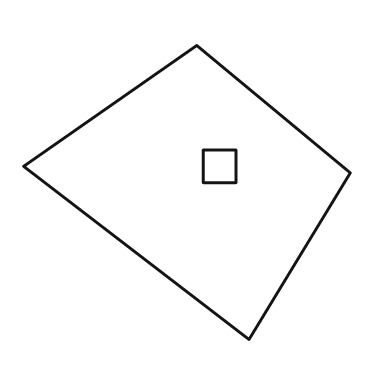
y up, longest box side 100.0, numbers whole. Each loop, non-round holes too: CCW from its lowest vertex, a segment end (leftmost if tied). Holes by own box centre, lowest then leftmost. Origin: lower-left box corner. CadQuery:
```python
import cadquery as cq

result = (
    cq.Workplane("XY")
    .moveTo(69.0, 0.0)
    .lineTo(100.0, 51.0)
    .lineTo(53.0, 90.0)
    .lineTo(0.0, 53.0)
    .close()
    .moveTo(55.0, 48.0)
    .lineTo(65.0, 48.0)
    .lineTo(65.0, 58.0)
    .lineTo(55.0, 58.0)
    .close()
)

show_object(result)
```